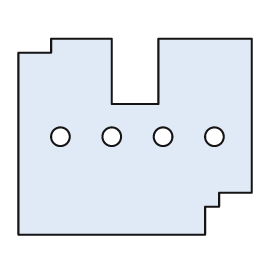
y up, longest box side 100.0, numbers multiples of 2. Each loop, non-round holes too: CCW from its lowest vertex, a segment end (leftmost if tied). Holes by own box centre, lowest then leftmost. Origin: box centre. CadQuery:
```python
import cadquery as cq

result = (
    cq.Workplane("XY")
    .moveTo(-50.0, -42.0)
    .lineTo(30.0, -42.0)
    .lineTo(30.0, -30.0)
    .lineTo(36.0, -30.0)
    .lineTo(36.0, -24.0)
    .lineTo(50.0, -24.0)
    .lineTo(50.0, 42.0)
    .lineTo(10.0, 42.0)
    .lineTo(10.0, 14.0)
    .lineTo(-10.0, 14.0)
    .lineTo(-10.0, 42.0)
    .lineTo(-36.0, 42.0)
    .lineTo(-36.0, 36.0)
    .lineTo(-50.0, 36.0)
    .close()
    .moveTo(-32.0, 0.0)
    .circle(4.0)
    .moveTo(-10.0, 0.0)
    .circle(4.0)
    .moveTo(12.0, 0.0)
    .circle(4.0)
    .moveTo(34.0, 0.0)
    .circle(4.0)
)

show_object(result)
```